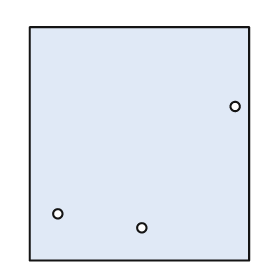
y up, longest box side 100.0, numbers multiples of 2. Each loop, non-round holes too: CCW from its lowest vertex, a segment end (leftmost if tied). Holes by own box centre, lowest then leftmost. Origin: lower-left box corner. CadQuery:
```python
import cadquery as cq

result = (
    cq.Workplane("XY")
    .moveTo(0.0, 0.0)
    .lineTo(94.0, 0.0)
    .lineTo(94.0, 100.0)
    .lineTo(0.0, 100.0)
    .close()
    .moveTo(48.0, 14.0)
    .circle(2.0)
    .moveTo(12.0, 20.0)
    .circle(2.0)
    .moveTo(88.0, 66.0)
    .circle(2.0)
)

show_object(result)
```